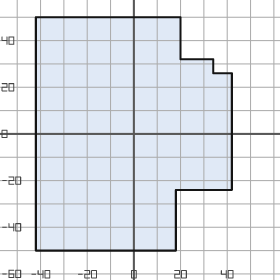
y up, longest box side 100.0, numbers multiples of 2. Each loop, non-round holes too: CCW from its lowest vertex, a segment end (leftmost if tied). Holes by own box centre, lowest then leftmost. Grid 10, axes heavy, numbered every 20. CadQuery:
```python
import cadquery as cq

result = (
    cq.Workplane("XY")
    .moveTo(-42.0, -50.0)
    .lineTo(18.0, -50.0)
    .lineTo(18.0, -24.0)
    .lineTo(42.0, -24.0)
    .lineTo(42.0, 26.0)
    .lineTo(34.0, 26.0)
    .lineTo(34.0, 32.0)
    .lineTo(20.0, 32.0)
    .lineTo(20.0, 50.0)
    .lineTo(-42.0, 50.0)
    .close()
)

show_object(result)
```